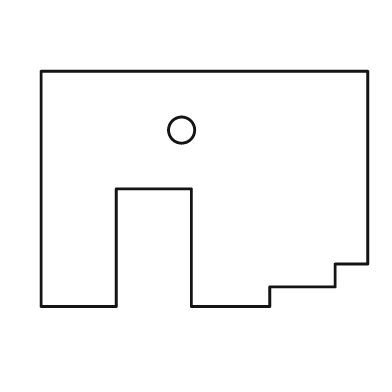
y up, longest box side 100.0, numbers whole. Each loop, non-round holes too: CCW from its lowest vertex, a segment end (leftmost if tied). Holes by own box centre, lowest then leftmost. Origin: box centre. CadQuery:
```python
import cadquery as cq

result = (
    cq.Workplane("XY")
    .moveTo(-50.0, -36.0)
    .lineTo(-27.0, -36.0)
    .lineTo(-27.0, 0.0)
    .lineTo(-4.0, 0.0)
    .lineTo(-4.0, -36.0)
    .lineTo(20.0, -36.0)
    .lineTo(20.0, -30.0)
    .lineTo(40.0, -30.0)
    .lineTo(40.0, -23.0)
    .lineTo(50.0, -23.0)
    .lineTo(50.0, 36.0)
    .lineTo(-50.0, 36.0)
    .close()
    .moveTo(-7.0, 18.0)
    .circle(4.0)
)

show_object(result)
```